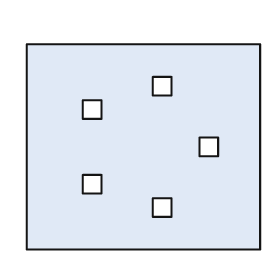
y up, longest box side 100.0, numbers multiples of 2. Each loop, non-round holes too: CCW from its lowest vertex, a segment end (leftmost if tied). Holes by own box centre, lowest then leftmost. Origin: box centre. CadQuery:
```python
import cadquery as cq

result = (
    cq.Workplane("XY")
    .moveTo(-50.0, -44.0)
    .lineTo(50.0, -44.0)
    .lineTo(50.0, 44.0)
    .lineTo(-50.0, 44.0)
    .close()
    .moveTo(4.0, -30.0)
    .lineTo(12.0, -30.0)
    .lineTo(12.0, -22.0)
    .lineTo(4.0, -22.0)
    .close()
    .moveTo(-26.0, -20.0)
    .lineTo(-18.0, -20.0)
    .lineTo(-18.0, -12.0)
    .lineTo(-26.0, -12.0)
    .close()
    .moveTo(24.0, -4.0)
    .lineTo(32.0, -4.0)
    .lineTo(32.0, 4.0)
    .lineTo(24.0, 4.0)
    .close()
    .moveTo(-26.0, 12.0)
    .lineTo(-18.0, 12.0)
    .lineTo(-18.0, 20.0)
    .lineTo(-26.0, 20.0)
    .close()
    .moveTo(4.0, 22.0)
    .lineTo(12.0, 22.0)
    .lineTo(12.0, 30.0)
    .lineTo(4.0, 30.0)
    .close()
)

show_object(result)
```